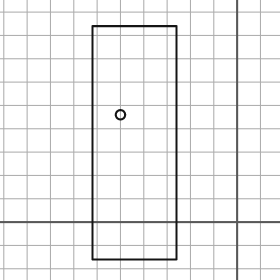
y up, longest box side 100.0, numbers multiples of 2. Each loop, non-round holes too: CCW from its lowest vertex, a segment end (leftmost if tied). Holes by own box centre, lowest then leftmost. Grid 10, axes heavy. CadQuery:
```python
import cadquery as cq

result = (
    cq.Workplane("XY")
    .moveTo(-62.0, -16.0)
    .lineTo(-26.0, -16.0)
    .lineTo(-26.0, 84.0)
    .lineTo(-62.0, 84.0)
    .close()
    .moveTo(-50.0, 46.0)
    .circle(2.0)
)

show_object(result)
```